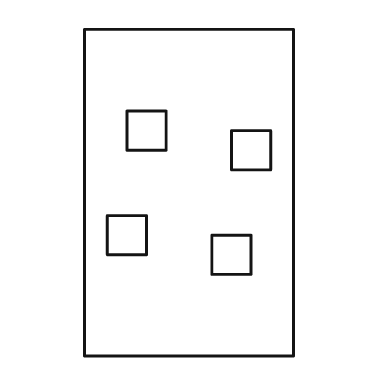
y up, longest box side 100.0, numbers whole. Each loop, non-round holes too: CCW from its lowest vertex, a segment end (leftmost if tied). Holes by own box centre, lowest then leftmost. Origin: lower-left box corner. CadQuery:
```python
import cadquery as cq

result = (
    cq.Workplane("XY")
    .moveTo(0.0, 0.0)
    .lineTo(64.0, 0.0)
    .lineTo(64.0, 100.0)
    .lineTo(0.0, 100.0)
    .close()
    .moveTo(39.0, 25.0)
    .lineTo(51.0, 25.0)
    .lineTo(51.0, 37.0)
    .lineTo(39.0, 37.0)
    .close()
    .moveTo(7.0, 31.0)
    .lineTo(19.0, 31.0)
    .lineTo(19.0, 43.0)
    .lineTo(7.0, 43.0)
    .close()
    .moveTo(45.0, 57.0)
    .lineTo(57.0, 57.0)
    .lineTo(57.0, 69.0)
    .lineTo(45.0, 69.0)
    .close()
    .moveTo(13.0, 63.0)
    .lineTo(25.0, 63.0)
    .lineTo(25.0, 75.0)
    .lineTo(13.0, 75.0)
    .close()
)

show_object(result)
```